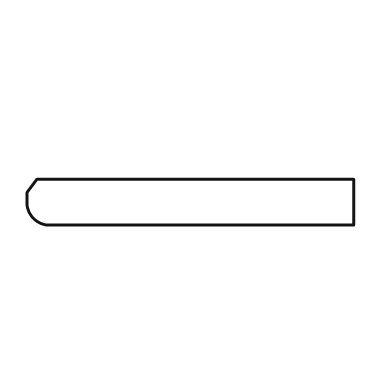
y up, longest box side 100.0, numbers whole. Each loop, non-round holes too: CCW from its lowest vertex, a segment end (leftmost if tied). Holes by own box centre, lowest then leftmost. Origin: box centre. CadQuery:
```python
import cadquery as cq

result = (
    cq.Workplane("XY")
    .moveTo(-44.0, -7.0)
    .lineTo(50.0, -7.0)
    .lineTo(50.0, 7.0)
    .lineTo(-47.0, 7.0)
    .lineTo(-50.0, 3.0)
    .lineTo(-50.0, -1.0)
    .threePointArc((-48.0, -5.0), (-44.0, -7.0))
    .close()
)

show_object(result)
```